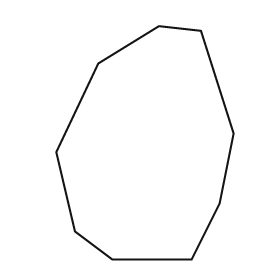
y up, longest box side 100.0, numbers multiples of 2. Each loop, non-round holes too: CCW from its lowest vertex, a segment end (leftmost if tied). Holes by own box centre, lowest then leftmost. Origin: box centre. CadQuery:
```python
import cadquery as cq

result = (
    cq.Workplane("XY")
    .moveTo(-14.0, -50.0)
    .lineTo(20.0, -50.0)
    .lineTo(32.0, -26.0)
    .lineTo(38.0, 4.0)
    .lineTo(24.0, 48.0)
    .lineTo(6.0, 50.0)
    .lineTo(-20.0, 34.0)
    .lineTo(-38.0, -4.0)
    .lineTo(-30.0, -38.0)
    .close()
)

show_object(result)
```